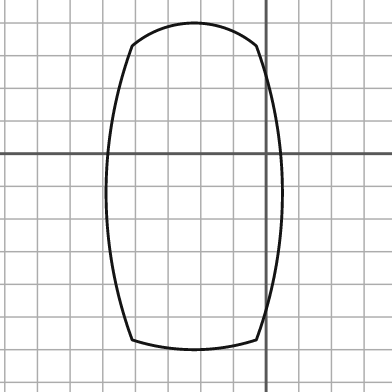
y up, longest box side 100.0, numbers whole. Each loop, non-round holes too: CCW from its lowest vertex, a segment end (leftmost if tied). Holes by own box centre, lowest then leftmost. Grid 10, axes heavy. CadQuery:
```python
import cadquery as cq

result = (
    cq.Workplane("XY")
    .moveTo(-41.0, -57.0)
    .threePointArc((-22.0, -60.0), (-3.0, -57.0))
    .threePointArc((5.0, -12.0), (-3.0, 33.0))
    .threePointArc((-22.0, 40.0), (-41.0, 33.0))
    .threePointArc((-49.0, -12.0), (-41.0, -57.0))
    .close()
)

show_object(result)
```